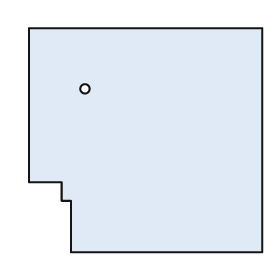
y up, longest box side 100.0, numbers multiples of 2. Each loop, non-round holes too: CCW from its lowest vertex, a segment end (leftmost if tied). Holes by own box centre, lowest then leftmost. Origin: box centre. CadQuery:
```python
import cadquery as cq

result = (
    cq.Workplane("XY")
    .moveTo(-32.0, -48.0)
    .lineTo(50.0, -48.0)
    .lineTo(50.0, 48.0)
    .lineTo(-50.0, 48.0)
    .lineTo(-50.0, -18.0)
    .lineTo(-36.0, -18.0)
    .lineTo(-36.0, -26.0)
    .lineTo(-32.0, -26.0)
    .close()
    .moveTo(-26.0, 22.0)
    .circle(2.0)
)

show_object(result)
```